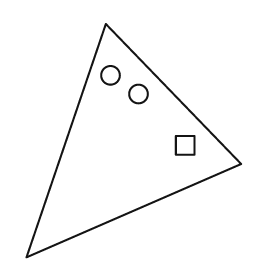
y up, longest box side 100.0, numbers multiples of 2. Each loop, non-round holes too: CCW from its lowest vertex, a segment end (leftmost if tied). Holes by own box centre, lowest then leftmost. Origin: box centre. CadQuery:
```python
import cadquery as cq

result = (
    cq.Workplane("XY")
    .moveTo(-46.0, -50.0)
    .lineTo(46.0, -10.0)
    .lineTo(-12.0, 50.0)
    .close()
    .moveTo(18.0, -6.0)
    .lineTo(26.0, -6.0)
    .lineTo(26.0, 2.0)
    .lineTo(18.0, 2.0)
    .close()
    .moveTo(2.0, 20.0)
    .circle(4.0)
    .moveTo(-10.0, 28.0)
    .circle(4.0)
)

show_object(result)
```